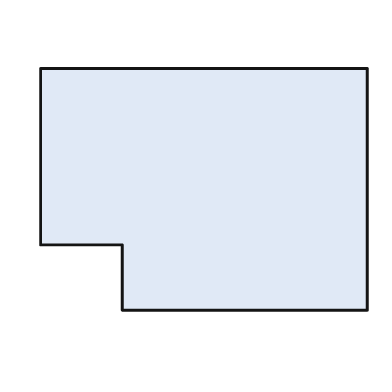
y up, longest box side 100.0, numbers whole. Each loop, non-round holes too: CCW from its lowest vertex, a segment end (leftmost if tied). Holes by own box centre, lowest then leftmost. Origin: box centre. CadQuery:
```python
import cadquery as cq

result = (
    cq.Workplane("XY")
    .moveTo(-25.0, -37.0)
    .lineTo(50.0, -37.0)
    .lineTo(50.0, 37.0)
    .lineTo(-50.0, 37.0)
    .lineTo(-50.0, -17.0)
    .lineTo(-25.0, -17.0)
    .close()
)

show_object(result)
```